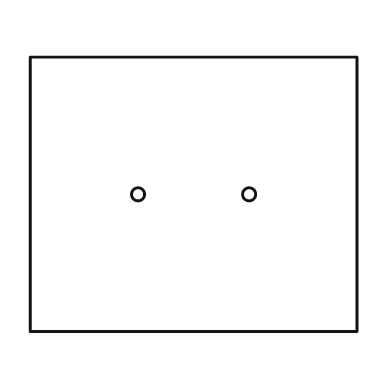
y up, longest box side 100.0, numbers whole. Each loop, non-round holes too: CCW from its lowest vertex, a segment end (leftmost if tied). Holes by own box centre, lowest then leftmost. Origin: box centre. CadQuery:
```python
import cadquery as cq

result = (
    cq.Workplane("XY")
    .moveTo(-50.0, -42.0)
    .lineTo(50.0, -42.0)
    .lineTo(50.0, 42.0)
    .lineTo(-50.0, 42.0)
    .close()
    .moveTo(-17.0, 0.0)
    .circle(2.0)
    .moveTo(17.0, 0.0)
    .circle(2.0)
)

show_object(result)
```